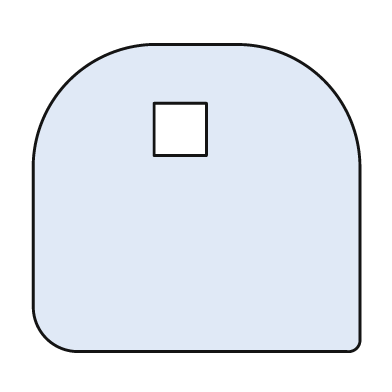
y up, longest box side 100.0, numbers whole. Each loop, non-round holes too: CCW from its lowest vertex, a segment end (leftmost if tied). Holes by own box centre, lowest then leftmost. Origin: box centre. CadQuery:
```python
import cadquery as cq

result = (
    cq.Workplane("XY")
    .moveTo(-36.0, -47.0)
    .lineTo(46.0, -47.0)
    .threePointArc((49.0, -46.0), (50.0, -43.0))
    .lineTo(50.0, 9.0)
    .threePointArc((39.0, 36.0), (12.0, 47.0))
    .lineTo(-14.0, 47.0)
    .threePointArc((-39.0, 36.0), (-50.0, 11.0))
    .lineTo(-50.0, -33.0)
    .threePointArc((-46.0, -43.0), (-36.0, -47.0))
    .close()
    .moveTo(-13.0, 13.0)
    .lineTo(3.0, 13.0)
    .lineTo(3.0, 29.0)
    .lineTo(-13.0, 29.0)
    .close()
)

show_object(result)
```